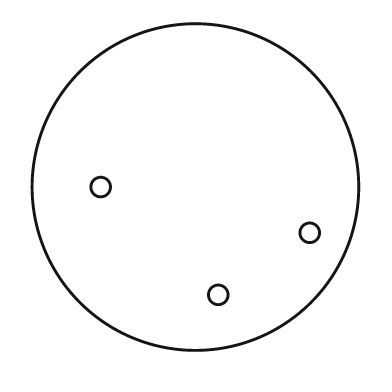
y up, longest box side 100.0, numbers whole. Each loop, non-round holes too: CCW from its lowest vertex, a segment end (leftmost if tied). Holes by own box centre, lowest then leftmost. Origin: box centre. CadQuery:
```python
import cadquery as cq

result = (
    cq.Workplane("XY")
    .moveTo(0.0, 0.0)
    .circle(50.0)
    .moveTo(7.0, -33.0)
    .circle(3.0)
    .moveTo(35.0, -14.0)
    .circle(3.0)
    .moveTo(-29.0, 0.0)
    .circle(3.0)
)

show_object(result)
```